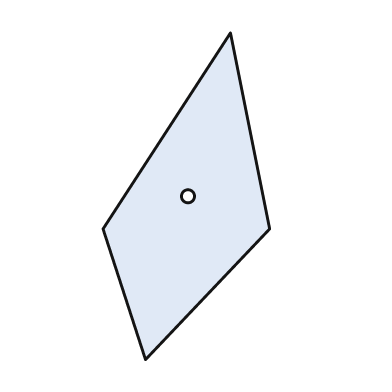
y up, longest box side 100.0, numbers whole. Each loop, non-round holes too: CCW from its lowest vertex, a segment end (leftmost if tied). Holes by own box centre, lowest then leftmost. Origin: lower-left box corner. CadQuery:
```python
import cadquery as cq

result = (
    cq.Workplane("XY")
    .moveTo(13.0, 0.0)
    .lineTo(51.0, 40.0)
    .lineTo(39.0, 100.0)
    .lineTo(0.0, 40.0)
    .close()
    .moveTo(26.0, 50.0)
    .circle(2.0)
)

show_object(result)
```